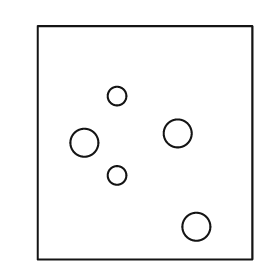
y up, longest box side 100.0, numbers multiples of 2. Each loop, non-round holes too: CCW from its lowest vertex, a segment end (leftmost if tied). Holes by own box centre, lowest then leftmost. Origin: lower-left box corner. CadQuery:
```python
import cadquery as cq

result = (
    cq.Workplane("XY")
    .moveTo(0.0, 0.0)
    .lineTo(92.0, 0.0)
    .lineTo(92.0, 100.0)
    .lineTo(0.0, 100.0)
    .close()
    .moveTo(68.0, 14.0)
    .circle(6.0)
    .moveTo(34.0, 36.0)
    .circle(4.0)
    .moveTo(20.0, 50.0)
    .circle(6.0)
    .moveTo(60.0, 54.0)
    .circle(6.0)
    .moveTo(34.0, 70.0)
    .circle(4.0)
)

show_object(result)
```